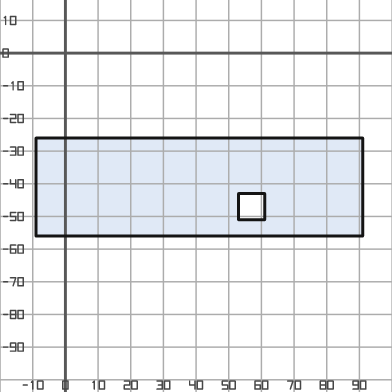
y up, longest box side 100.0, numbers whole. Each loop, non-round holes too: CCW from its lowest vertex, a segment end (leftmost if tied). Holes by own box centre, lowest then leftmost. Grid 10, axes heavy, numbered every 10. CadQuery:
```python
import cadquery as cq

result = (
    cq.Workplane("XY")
    .moveTo(-9.0, -56.0)
    .lineTo(91.0, -56.0)
    .lineTo(91.0, -26.0)
    .lineTo(-9.0, -26.0)
    .close()
    .moveTo(53.0, -51.0)
    .lineTo(61.0, -51.0)
    .lineTo(61.0, -43.0)
    .lineTo(53.0, -43.0)
    .close()
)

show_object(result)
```